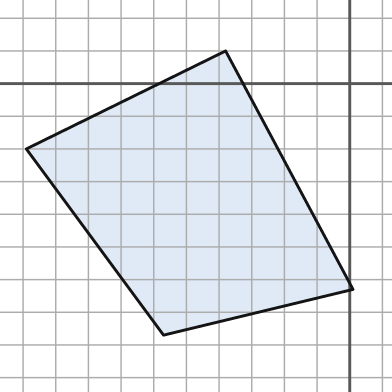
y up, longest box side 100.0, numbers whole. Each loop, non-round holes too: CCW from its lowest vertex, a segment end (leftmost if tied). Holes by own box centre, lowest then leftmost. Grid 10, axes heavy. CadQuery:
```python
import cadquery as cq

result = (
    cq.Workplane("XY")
    .moveTo(-57.0, -77.0)
    .lineTo(1.0, -63.0)
    .lineTo(-38.0, 10.0)
    .lineTo(-99.0, -20.0)
    .close()
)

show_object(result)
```